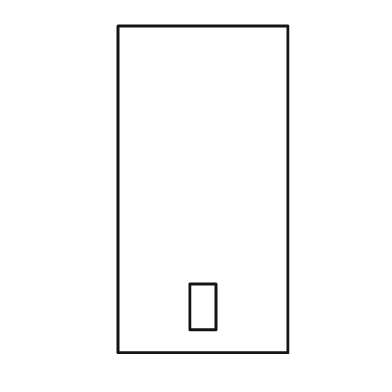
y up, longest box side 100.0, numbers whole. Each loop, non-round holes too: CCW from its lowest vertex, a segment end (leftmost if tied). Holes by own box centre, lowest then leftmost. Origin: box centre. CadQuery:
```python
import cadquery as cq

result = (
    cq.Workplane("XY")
    .moveTo(-26.0, -50.0)
    .lineTo(26.0, -50.0)
    .lineTo(26.0, 50.0)
    .lineTo(-26.0, 50.0)
    .close()
    .moveTo(-4.0, -43.0)
    .lineTo(4.0, -43.0)
    .lineTo(4.0, -29.0)
    .lineTo(-4.0, -29.0)
    .close()
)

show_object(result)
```